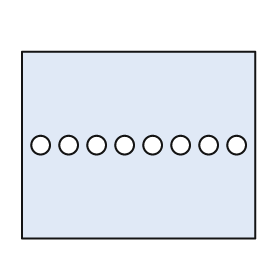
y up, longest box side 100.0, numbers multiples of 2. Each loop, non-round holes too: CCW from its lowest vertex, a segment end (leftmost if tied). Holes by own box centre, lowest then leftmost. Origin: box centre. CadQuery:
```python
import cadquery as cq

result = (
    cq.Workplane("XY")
    .moveTo(-50.0, -40.0)
    .lineTo(50.0, -40.0)
    .lineTo(50.0, 40.0)
    .lineTo(-50.0, 40.0)
    .close()
    .moveTo(-42.0, 0.0)
    .circle(4.0)
    .moveTo(-30.0, 0.0)
    .circle(4.0)
    .moveTo(-18.0, 0.0)
    .circle(4.0)
    .moveTo(-6.0, 0.0)
    .circle(4.0)
    .moveTo(6.0, 0.0)
    .circle(4.0)
    .moveTo(18.0, 0.0)
    .circle(4.0)
    .moveTo(30.0, 0.0)
    .circle(4.0)
    .moveTo(42.0, 0.0)
    .circle(4.0)
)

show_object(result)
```